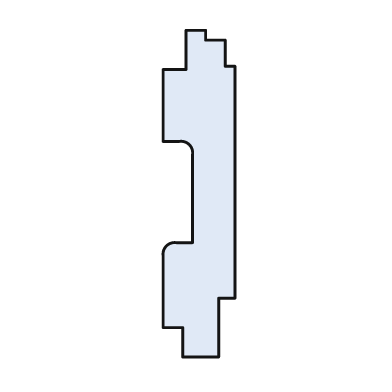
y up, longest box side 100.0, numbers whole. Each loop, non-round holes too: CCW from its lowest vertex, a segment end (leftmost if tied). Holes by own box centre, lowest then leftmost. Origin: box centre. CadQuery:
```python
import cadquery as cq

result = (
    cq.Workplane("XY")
    .moveTo(-5.0, -50.0)
    .lineTo(6.0, -50.0)
    .lineTo(6.0, -32.0)
    .lineTo(11.0, -32.0)
    .lineTo(11.0, 39.0)
    .lineTo(8.0, 39.0)
    .lineTo(8.0, 47.0)
    .lineTo(2.0, 47.0)
    .lineTo(2.0, 50.0)
    .lineTo(-4.0, 50.0)
    .lineTo(-4.0, 38.0)
    .lineTo(-11.0, 38.0)
    .lineTo(-11.0, 16.0)
    .lineTo(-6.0, 16.0)
    .threePointArc((-3.0, 15.0), (-2.0, 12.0))
    .lineTo(-2.0, -15.0)
    .lineTo(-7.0, -15.0)
    .threePointArc((-10.0, -16.0), (-11.0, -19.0))
    .lineTo(-11.0, -41.0)
    .lineTo(-5.0, -41.0)
    .close()
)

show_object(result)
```